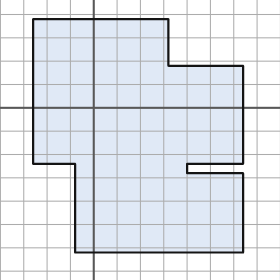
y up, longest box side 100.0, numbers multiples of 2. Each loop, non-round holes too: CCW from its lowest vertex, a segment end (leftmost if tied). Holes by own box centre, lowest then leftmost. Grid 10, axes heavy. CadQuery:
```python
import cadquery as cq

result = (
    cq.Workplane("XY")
    .moveTo(-8.0, -62.0)
    .lineTo(64.0, -62.0)
    .lineTo(64.0, -28.0)
    .lineTo(40.0, -28.0)
    .lineTo(40.0, -24.0)
    .lineTo(64.0, -24.0)
    .lineTo(64.0, 18.0)
    .lineTo(32.0, 18.0)
    .lineTo(32.0, 38.0)
    .lineTo(-26.0, 38.0)
    .lineTo(-26.0, -24.0)
    .lineTo(-8.0, -24.0)
    .close()
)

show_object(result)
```